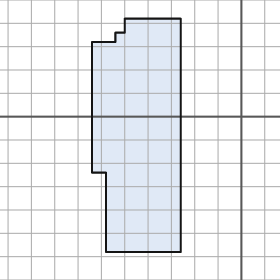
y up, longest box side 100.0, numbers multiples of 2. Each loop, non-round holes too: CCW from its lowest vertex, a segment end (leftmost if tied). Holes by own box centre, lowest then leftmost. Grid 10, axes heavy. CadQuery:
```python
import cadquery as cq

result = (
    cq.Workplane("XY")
    .moveTo(-58.0, -58.0)
    .lineTo(-26.0, -58.0)
    .lineTo(-26.0, 42.0)
    .lineTo(-50.0, 42.0)
    .lineTo(-50.0, 36.0)
    .lineTo(-54.0, 36.0)
    .lineTo(-54.0, 32.0)
    .lineTo(-64.0, 32.0)
    .lineTo(-64.0, -24.0)
    .lineTo(-58.0, -24.0)
    .close()
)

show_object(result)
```